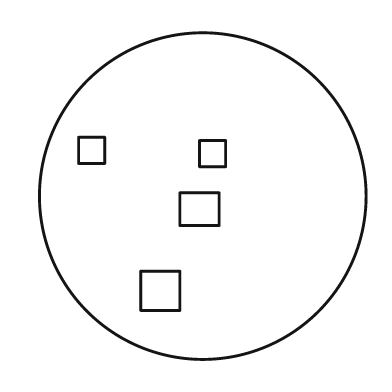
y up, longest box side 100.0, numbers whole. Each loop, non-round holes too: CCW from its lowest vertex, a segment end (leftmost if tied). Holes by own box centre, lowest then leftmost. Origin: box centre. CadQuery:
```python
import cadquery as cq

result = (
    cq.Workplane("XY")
    .moveTo(0.0, 0.0)
    .circle(50.0)
    .moveTo(-19.0, -35.0)
    .lineTo(-7.0, -35.0)
    .lineTo(-7.0, -23.0)
    .lineTo(-19.0, -23.0)
    .close()
    .moveTo(-7.0, -9.0)
    .lineTo(5.0, -9.0)
    .lineTo(5.0, 1.0)
    .lineTo(-7.0, 1.0)
    .close()
    .moveTo(-1.0, 9.0)
    .lineTo(7.0, 9.0)
    .lineTo(7.0, 17.0)
    .lineTo(-1.0, 17.0)
    .close()
    .moveTo(-38.0, 10.0)
    .lineTo(-30.0, 10.0)
    .lineTo(-30.0, 18.0)
    .lineTo(-38.0, 18.0)
    .close()
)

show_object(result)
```